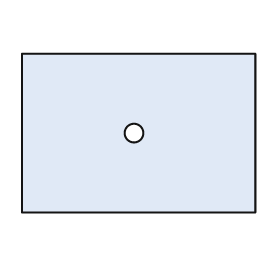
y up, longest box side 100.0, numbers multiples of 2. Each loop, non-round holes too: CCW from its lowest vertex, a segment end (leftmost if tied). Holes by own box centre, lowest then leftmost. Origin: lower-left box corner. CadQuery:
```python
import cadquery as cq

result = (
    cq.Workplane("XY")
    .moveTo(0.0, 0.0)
    .lineTo(100.0, 0.0)
    .lineTo(100.0, 68.0)
    .lineTo(0.0, 68.0)
    .close()
    .moveTo(48.0, 34.0)
    .circle(4.0)
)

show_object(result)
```